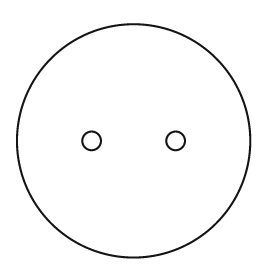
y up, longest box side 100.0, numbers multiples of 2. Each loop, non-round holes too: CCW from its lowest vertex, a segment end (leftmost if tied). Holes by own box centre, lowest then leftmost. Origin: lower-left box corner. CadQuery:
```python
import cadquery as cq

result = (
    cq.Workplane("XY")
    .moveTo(50.0, 50.0)
    .circle(50.0)
    .moveTo(32.0, 50.0)
    .circle(4.0)
    .moveTo(68.0, 50.0)
    .circle(4.0)
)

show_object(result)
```